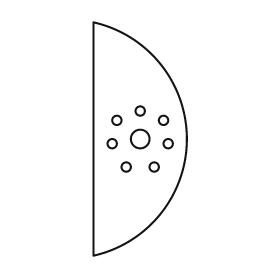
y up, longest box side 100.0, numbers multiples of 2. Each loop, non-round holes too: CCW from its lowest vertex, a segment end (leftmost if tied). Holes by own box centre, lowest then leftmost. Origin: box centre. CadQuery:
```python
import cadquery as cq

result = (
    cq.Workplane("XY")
    .moveTo(-20.0, -50.0)
    .threePointArc((20.0, 0.0), (-20.0, 50.0))
    .close()
    .moveTo(-6.0, -12.0)
    .circle(2.0)
    .moveTo(6.0, -12.0)
    .circle(2.0)
    .moveTo(-12.0, -2.0)
    .circle(2.0)
    .moveTo(12.0, -2.0)
    .circle(2.0)
    .moveTo(0.0, 0.0)
    .circle(4.0)
    .moveTo(-10.0, 8.0)
    .circle(2.0)
    .moveTo(10.0, 8.0)
    .circle(2.0)
    .moveTo(0.0, 12.0)
    .circle(2.0)
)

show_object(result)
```